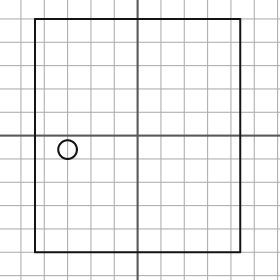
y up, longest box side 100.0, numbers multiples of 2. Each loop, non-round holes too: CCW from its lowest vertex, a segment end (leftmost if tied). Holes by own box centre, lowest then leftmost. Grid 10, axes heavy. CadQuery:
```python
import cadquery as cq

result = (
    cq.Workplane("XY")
    .moveTo(-44.0, -50.0)
    .lineTo(44.0, -50.0)
    .lineTo(44.0, 50.0)
    .lineTo(-44.0, 50.0)
    .close()
    .moveTo(-30.0, -6.0)
    .circle(4.0)
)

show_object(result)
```